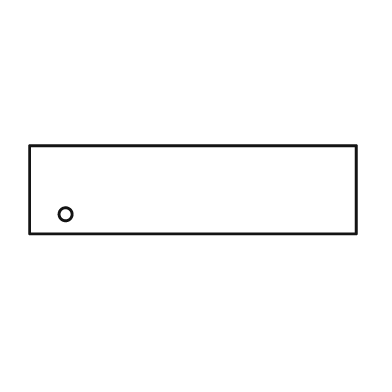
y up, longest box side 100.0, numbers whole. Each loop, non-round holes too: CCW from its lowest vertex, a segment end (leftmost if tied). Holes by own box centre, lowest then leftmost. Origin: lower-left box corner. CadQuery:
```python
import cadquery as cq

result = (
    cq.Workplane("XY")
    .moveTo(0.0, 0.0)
    .lineTo(100.0, 0.0)
    .lineTo(100.0, 27.0)
    .lineTo(0.0, 27.0)
    .close()
    .moveTo(11.0, 6.0)
    .circle(2.0)
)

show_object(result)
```